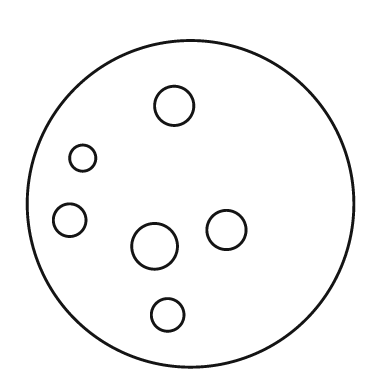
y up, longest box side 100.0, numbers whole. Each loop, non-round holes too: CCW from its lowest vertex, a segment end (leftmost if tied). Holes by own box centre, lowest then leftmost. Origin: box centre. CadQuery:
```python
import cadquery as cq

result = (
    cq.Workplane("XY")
    .moveTo(0.0, 0.0)
    .circle(50.0)
    .moveTo(-7.0, -34.0)
    .circle(5.0)
    .moveTo(-11.0, -13.0)
    .circle(7.0)
    .moveTo(11.0, -8.0)
    .circle(6.0)
    .moveTo(-37.0, -5.0)
    .circle(5.0)
    .moveTo(-33.0, 14.0)
    .circle(4.0)
    .moveTo(-5.0, 30.0)
    .circle(6.0)
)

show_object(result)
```